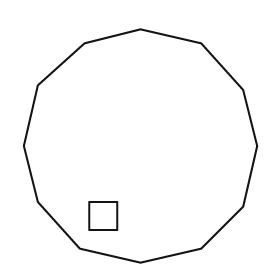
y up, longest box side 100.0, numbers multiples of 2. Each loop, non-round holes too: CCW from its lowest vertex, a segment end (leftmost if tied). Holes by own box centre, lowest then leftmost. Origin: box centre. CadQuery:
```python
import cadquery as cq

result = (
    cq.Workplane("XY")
    .moveTo(0.0, -50.0)
    .lineTo(26.0, -44.0)
    .lineTo(44.0, -26.0)
    .lineTo(50.0, 0.0)
    .lineTo(44.0, 24.0)
    .lineTo(26.0, 44.0)
    .lineTo(0.0, 50.0)
    .lineTo(-24.0, 44.0)
    .lineTo(-44.0, 26.0)
    .lineTo(-50.0, 0.0)
    .lineTo(-44.0, -24.0)
    .lineTo(-26.0, -44.0)
    .close()
    .moveTo(-22.0, -36.0)
    .lineTo(-10.0, -36.0)
    .lineTo(-10.0, -24.0)
    .lineTo(-22.0, -24.0)
    .close()
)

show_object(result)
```